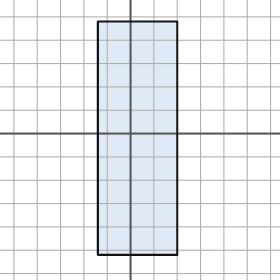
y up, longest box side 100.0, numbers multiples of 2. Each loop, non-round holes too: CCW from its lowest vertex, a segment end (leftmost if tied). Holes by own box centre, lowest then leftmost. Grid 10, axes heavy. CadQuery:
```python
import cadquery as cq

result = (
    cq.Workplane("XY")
    .moveTo(-14.0, -52.0)
    .lineTo(20.0, -52.0)
    .lineTo(20.0, 48.0)
    .lineTo(-14.0, 48.0)
    .close()
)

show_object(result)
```